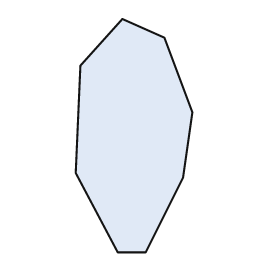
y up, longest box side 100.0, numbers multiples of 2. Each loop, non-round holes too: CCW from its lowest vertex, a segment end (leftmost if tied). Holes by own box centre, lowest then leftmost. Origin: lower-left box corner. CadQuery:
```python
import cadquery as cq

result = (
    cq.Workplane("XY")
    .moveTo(18.0, 0.0)
    .lineTo(30.0, 0.0)
    .lineTo(46.0, 32.0)
    .lineTo(50.0, 60.0)
    .lineTo(38.0, 92.0)
    .lineTo(20.0, 100.0)
    .lineTo(2.0, 80.0)
    .lineTo(0.0, 34.0)
    .close()
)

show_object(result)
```